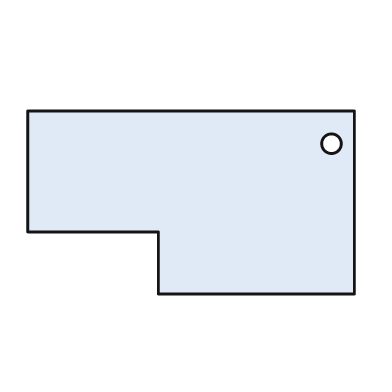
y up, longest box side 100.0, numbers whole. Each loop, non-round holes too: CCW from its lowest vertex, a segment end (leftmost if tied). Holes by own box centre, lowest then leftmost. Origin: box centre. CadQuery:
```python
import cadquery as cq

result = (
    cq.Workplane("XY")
    .moveTo(-10.0, -28.0)
    .lineTo(50.0, -28.0)
    .lineTo(50.0, 28.0)
    .lineTo(-50.0, 28.0)
    .lineTo(-50.0, -9.0)
    .lineTo(-10.0, -9.0)
    .close()
    .moveTo(43.0, 18.0)
    .circle(3.0)
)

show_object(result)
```